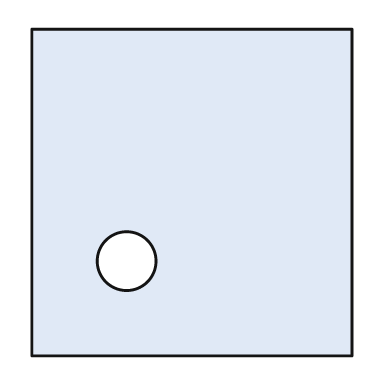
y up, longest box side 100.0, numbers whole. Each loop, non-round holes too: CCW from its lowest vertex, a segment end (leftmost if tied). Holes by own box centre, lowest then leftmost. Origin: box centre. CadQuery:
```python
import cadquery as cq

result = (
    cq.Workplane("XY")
    .moveTo(-49.0, -50.0)
    .lineTo(49.0, -50.0)
    .lineTo(49.0, 50.0)
    .lineTo(-49.0, 50.0)
    .close()
    .moveTo(-20.0, -21.0)
    .circle(9.0)
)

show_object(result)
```